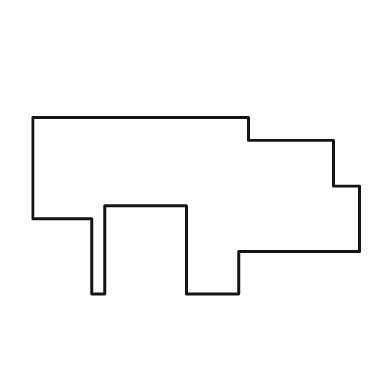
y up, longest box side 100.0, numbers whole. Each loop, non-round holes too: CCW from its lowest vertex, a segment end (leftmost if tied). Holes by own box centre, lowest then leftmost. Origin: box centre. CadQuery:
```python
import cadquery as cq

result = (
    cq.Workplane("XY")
    .moveTo(-32.0, -27.0)
    .lineTo(-28.0, -27.0)
    .lineTo(-28.0, 0.0)
    .lineTo(-3.0, 0.0)
    .lineTo(-3.0, -27.0)
    .lineTo(13.0, -27.0)
    .lineTo(13.0, -14.0)
    .lineTo(50.0, -14.0)
    .lineTo(50.0, 6.0)
    .lineTo(42.0, 6.0)
    .lineTo(42.0, 20.0)
    .lineTo(16.0, 20.0)
    .lineTo(16.0, 27.0)
    .lineTo(-50.0, 27.0)
    .lineTo(-50.0, -4.0)
    .lineTo(-32.0, -4.0)
    .close()
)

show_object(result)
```